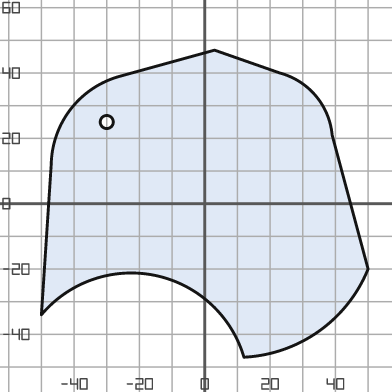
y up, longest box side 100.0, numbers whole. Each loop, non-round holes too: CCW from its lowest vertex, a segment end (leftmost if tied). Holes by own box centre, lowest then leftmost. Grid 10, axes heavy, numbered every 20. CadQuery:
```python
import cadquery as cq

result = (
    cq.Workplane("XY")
    .moveTo(12.0, -47.0)
    .threePointArc((35.0, -39.0), (50.0, -20.0))
    .lineTo(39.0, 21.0)
    .threePointArc((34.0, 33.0), (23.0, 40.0))
    .lineTo(3.0, 47.0)
    .lineTo(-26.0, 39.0)
    .threePointArc((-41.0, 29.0), (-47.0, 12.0))
    .lineTo(-50.0, -34.0)
    .threePointArc((-15.0, -22.0), (12.0, -47.0))
    .close()
    .moveTo(-30.0, 25.0)
    .circle(2.0)
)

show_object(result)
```